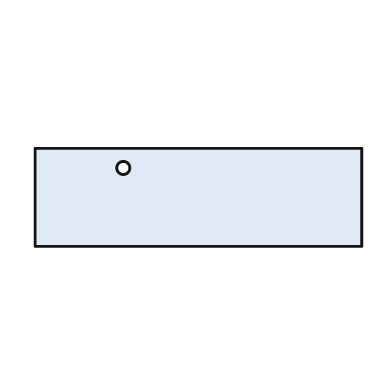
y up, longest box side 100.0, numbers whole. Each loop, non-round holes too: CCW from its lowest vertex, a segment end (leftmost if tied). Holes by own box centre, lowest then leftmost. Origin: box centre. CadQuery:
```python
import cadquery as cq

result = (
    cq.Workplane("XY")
    .moveTo(-50.0, -15.0)
    .lineTo(50.0, -15.0)
    .lineTo(50.0, 15.0)
    .lineTo(-50.0, 15.0)
    .close()
    .moveTo(-23.0, 9.0)
    .circle(2.0)
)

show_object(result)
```